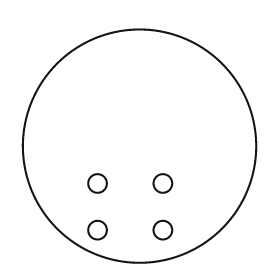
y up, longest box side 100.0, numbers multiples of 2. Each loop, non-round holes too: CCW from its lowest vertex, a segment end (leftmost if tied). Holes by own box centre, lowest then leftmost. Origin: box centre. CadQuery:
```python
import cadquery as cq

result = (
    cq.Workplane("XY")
    .moveTo(0.0, 0.0)
    .circle(50.0)
    .moveTo(-18.0, -36.0)
    .circle(4.0)
    .moveTo(10.0, -36.0)
    .circle(4.0)
    .moveTo(-18.0, -16.0)
    .circle(4.0)
    .moveTo(10.0, -16.0)
    .circle(4.0)
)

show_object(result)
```